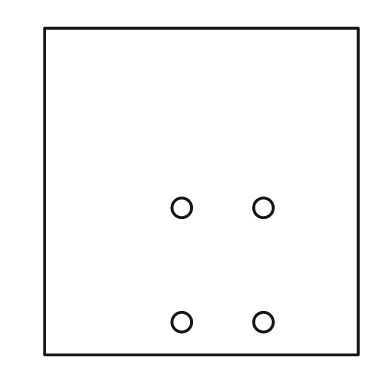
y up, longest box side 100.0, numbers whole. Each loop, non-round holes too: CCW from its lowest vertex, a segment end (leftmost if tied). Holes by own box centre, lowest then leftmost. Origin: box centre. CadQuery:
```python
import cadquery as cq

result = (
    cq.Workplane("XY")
    .moveTo(-48.0, -50.0)
    .lineTo(48.0, -50.0)
    .lineTo(48.0, 50.0)
    .lineTo(-48.0, 50.0)
    .close()
    .moveTo(-6.0, -40.0)
    .circle(3.0)
    .moveTo(19.0, -40.0)
    .circle(3.0)
    .moveTo(-6.0, -5.0)
    .circle(3.0)
    .moveTo(19.0, -5.0)
    .circle(3.0)
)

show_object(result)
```